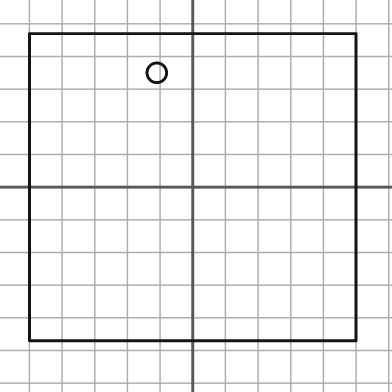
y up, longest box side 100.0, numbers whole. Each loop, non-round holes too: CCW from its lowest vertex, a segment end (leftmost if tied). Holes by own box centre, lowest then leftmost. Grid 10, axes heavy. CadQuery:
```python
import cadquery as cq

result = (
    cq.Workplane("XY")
    .moveTo(-50.0, -47.0)
    .lineTo(50.0, -47.0)
    .lineTo(50.0, 47.0)
    .lineTo(-50.0, 47.0)
    .close()
    .moveTo(-11.0, 35.0)
    .circle(3.0)
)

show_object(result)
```